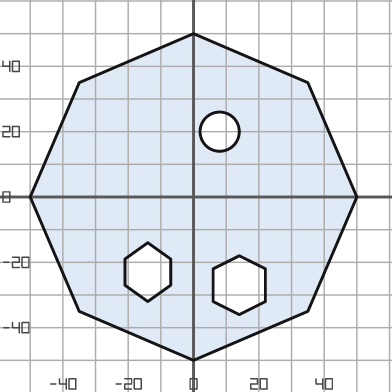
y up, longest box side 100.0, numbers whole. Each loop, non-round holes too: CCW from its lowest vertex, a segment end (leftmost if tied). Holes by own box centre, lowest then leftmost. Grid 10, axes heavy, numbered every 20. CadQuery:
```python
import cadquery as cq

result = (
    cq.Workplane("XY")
    .moveTo(0.0, -50.0)
    .lineTo(35.0, -35.0)
    .lineTo(50.0, 0.0)
    .lineTo(35.0, 35.0)
    .lineTo(0.0, 50.0)
    .lineTo(-35.0, 35.0)
    .lineTo(-50.0, 0.0)
    .lineTo(-35.0, -35.0)
    .close()
    .moveTo(14.0, -36.0)
    .lineTo(22.0, -32.0)
    .lineTo(22.0, -22.0)
    .lineTo(14.0, -18.0)
    .lineTo(6.0, -22.0)
    .lineTo(6.0, -32.0)
    .close()
    .moveTo(-14.0, -32.0)
    .lineTo(-7.0, -27.0)
    .lineTo(-7.0, -19.0)
    .lineTo(-14.0, -14.0)
    .lineTo(-21.0, -19.0)
    .lineTo(-21.0, -27.0)
    .close()
    .moveTo(8.0, 20.0)
    .circle(6.0)
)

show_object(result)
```